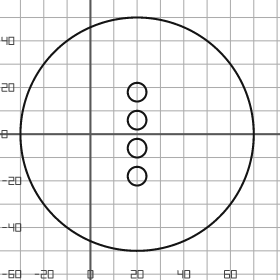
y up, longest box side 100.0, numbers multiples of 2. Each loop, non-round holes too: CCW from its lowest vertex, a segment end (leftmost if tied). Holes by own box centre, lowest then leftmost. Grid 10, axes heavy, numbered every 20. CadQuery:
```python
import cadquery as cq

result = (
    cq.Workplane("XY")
    .moveTo(20.0, 0.0)
    .circle(50.0)
    .moveTo(20.0, -18.0)
    .circle(4.0)
    .moveTo(20.0, -6.0)
    .circle(4.0)
    .moveTo(20.0, 6.0)
    .circle(4.0)
    .moveTo(20.0, 18.0)
    .circle(4.0)
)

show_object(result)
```